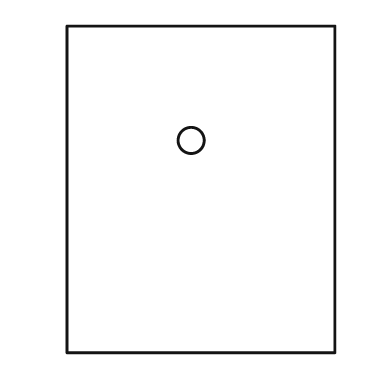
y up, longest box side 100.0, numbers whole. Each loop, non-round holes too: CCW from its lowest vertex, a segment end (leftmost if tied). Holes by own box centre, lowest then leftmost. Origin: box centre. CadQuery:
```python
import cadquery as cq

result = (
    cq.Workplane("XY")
    .moveTo(-41.0, -50.0)
    .lineTo(41.0, -50.0)
    .lineTo(41.0, 50.0)
    .lineTo(-41.0, 50.0)
    .close()
    .moveTo(-3.0, 15.0)
    .circle(4.0)
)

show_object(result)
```